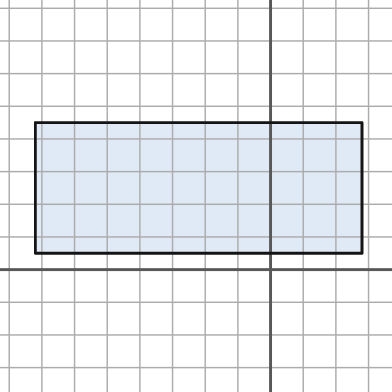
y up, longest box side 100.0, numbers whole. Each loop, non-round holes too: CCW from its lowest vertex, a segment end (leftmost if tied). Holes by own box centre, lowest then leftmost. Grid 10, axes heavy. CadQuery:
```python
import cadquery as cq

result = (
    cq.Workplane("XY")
    .moveTo(-72.0, 5.0)
    .lineTo(28.0, 5.0)
    .lineTo(28.0, 45.0)
    .lineTo(-72.0, 45.0)
    .close()
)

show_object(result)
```